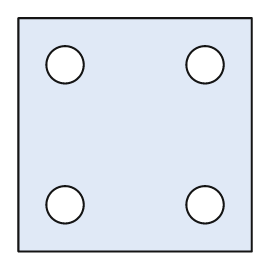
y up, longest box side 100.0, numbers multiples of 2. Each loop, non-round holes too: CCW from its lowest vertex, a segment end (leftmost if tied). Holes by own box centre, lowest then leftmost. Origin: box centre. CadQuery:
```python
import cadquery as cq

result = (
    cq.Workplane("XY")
    .moveTo(-50.0, -50.0)
    .lineTo(50.0, -50.0)
    .lineTo(50.0, 50.0)
    .lineTo(-50.0, 50.0)
    .close()
    .moveTo(-30.0, -30.0)
    .circle(8.0)
    .moveTo(30.0, -30.0)
    .circle(8.0)
    .moveTo(-30.0, 30.0)
    .circle(8.0)
    .moveTo(30.0, 30.0)
    .circle(8.0)
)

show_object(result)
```